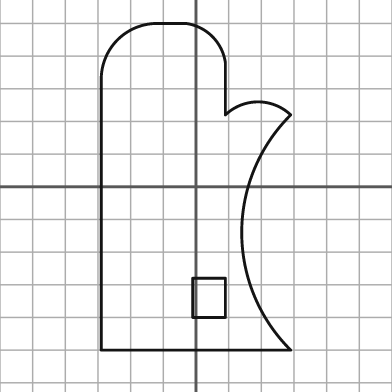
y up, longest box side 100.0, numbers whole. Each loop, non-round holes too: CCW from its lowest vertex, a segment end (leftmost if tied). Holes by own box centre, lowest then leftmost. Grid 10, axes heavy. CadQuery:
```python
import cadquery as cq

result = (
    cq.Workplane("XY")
    .moveTo(-29.0, -50.0)
    .lineTo(29.0, -50.0)
    .threePointArc((14.0, -14.0), (29.0, 22.0))
    .threePointArc((19.0, 26.0), (9.0, 22.0))
    .lineTo(9.0, 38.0)
    .threePointArc((5.0, 46.0), (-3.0, 50.0))
    .lineTo(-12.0, 50.0)
    .threePointArc((-24.0, 45.0), (-29.0, 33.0))
    .close()
    .moveTo(-1.0, -40.0)
    .lineTo(9.0, -40.0)
    .lineTo(9.0, -28.0)
    .lineTo(-1.0, -28.0)
    .close()
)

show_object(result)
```